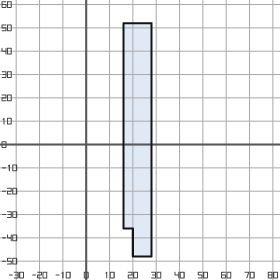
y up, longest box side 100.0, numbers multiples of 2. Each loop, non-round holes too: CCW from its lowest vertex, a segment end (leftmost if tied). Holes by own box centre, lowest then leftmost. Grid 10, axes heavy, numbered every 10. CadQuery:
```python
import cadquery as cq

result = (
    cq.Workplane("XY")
    .moveTo(20.0, -48.0)
    .lineTo(28.0, -48.0)
    .lineTo(28.0, 52.0)
    .lineTo(16.0, 52.0)
    .lineTo(16.0, -36.0)
    .lineTo(20.0, -36.0)
    .close()
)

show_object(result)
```